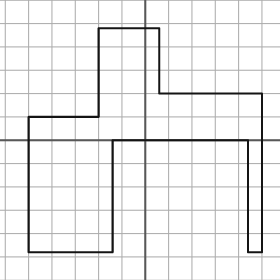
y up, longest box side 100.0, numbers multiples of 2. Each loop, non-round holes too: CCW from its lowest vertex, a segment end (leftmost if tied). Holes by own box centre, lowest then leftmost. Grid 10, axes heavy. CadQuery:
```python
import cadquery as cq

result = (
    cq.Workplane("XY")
    .moveTo(-50.0, -48.0)
    .lineTo(-14.0, -48.0)
    .lineTo(-14.0, 0.0)
    .lineTo(44.0, 0.0)
    .lineTo(44.0, -48.0)
    .lineTo(50.0, -48.0)
    .lineTo(50.0, 20.0)
    .lineTo(6.0, 20.0)
    .lineTo(6.0, 48.0)
    .lineTo(-20.0, 48.0)
    .lineTo(-20.0, 10.0)
    .lineTo(-50.0, 10.0)
    .close()
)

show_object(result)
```